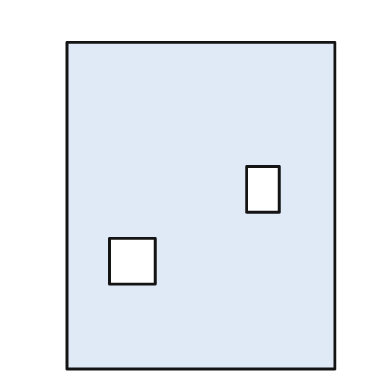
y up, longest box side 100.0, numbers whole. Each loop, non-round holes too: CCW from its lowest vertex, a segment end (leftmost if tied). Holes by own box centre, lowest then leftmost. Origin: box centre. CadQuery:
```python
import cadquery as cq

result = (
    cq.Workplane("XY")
    .moveTo(-41.0, -50.0)
    .lineTo(41.0, -50.0)
    .lineTo(41.0, 50.0)
    .lineTo(-41.0, 50.0)
    .close()
    .moveTo(-28.0, -24.0)
    .lineTo(-14.0, -24.0)
    .lineTo(-14.0, -10.0)
    .lineTo(-28.0, -10.0)
    .close()
    .moveTo(14.0, -2.0)
    .lineTo(24.0, -2.0)
    .lineTo(24.0, 12.0)
    .lineTo(14.0, 12.0)
    .close()
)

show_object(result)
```